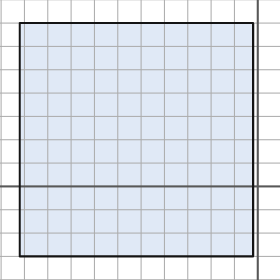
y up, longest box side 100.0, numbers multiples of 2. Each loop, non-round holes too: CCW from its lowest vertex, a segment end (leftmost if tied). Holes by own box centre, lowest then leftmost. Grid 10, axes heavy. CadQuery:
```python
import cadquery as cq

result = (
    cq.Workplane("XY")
    .moveTo(-102.0, -30.0)
    .lineTo(-2.0, -30.0)
    .lineTo(-2.0, 70.0)
    .lineTo(-102.0, 70.0)
    .close()
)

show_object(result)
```